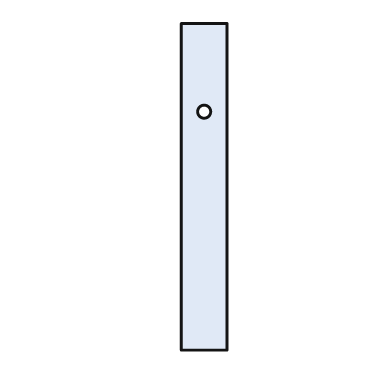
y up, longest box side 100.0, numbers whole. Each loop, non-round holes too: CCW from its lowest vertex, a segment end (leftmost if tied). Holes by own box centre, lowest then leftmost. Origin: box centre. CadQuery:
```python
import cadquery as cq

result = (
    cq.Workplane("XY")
    .moveTo(-7.0, -50.0)
    .lineTo(7.0, -50.0)
    .lineTo(7.0, 50.0)
    .lineTo(-7.0, 50.0)
    .close()
    .moveTo(0.0, 23.0)
    .circle(2.0)
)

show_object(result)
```